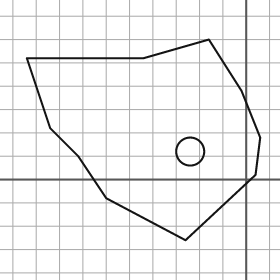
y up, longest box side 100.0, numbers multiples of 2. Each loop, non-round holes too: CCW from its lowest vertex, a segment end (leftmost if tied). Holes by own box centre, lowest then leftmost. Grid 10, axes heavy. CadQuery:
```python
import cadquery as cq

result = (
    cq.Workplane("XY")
    .moveTo(-26.0, -26.0)
    .lineTo(4.0, 2.0)
    .lineTo(6.0, 18.0)
    .lineTo(-2.0, 38.0)
    .lineTo(-16.0, 60.0)
    .lineTo(-44.0, 52.0)
    .lineTo(-94.0, 52.0)
    .lineTo(-84.0, 22.0)
    .lineTo(-72.0, 10.0)
    .lineTo(-60.0, -8.0)
    .close()
    .moveTo(-24.0, 12.0)
    .circle(6.0)
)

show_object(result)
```